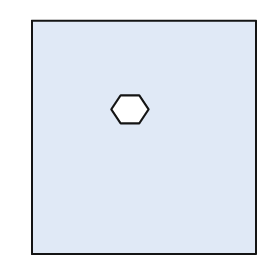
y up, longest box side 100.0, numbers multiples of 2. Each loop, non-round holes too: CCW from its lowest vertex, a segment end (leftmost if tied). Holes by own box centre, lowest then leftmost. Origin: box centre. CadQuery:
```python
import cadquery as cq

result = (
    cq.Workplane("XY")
    .moveTo(-48.0, -50.0)
    .lineTo(48.0, -50.0)
    .lineTo(48.0, 50.0)
    .lineTo(-48.0, 50.0)
    .close()
    .moveTo(-10.0, 6.0)
    .lineTo(-2.0, 6.0)
    .lineTo(2.0, 12.0)
    .lineTo(-2.0, 18.0)
    .lineTo(-10.0, 18.0)
    .lineTo(-14.0, 12.0)
    .close()
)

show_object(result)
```